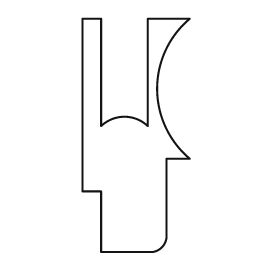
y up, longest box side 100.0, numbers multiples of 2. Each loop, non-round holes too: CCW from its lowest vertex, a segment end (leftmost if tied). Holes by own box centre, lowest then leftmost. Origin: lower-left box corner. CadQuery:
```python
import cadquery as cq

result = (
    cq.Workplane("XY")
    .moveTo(8.0, 0.0)
    .lineTo(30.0, 0.0)
    .threePointArc((34.0, 2.0), (36.0, 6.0))
    .lineTo(36.0, 40.0)
    .lineTo(46.0, 40.0)
    .threePointArc((32.0, 70.0), (46.0, 100.0))
    .lineTo(28.0, 100.0)
    .lineTo(28.0, 54.0)
    .threePointArc((18.0, 58.0), (8.0, 54.0))
    .lineTo(8.0, 100.0)
    .lineTo(0.0, 100.0)
    .lineTo(0.0, 26.0)
    .lineTo(8.0, 26.0)
    .close()
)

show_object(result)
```